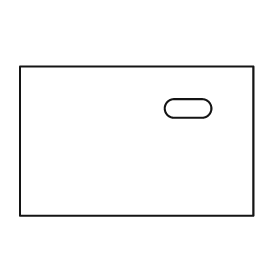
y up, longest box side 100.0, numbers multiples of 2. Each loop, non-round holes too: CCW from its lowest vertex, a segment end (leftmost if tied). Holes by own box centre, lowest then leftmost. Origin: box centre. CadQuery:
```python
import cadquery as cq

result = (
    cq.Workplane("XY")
    .moveTo(-50.0, -32.0)
    .lineTo(50.0, -32.0)
    .lineTo(50.0, 32.0)
    .lineTo(-50.0, 32.0)
    .close()
    .moveTo(16.0, 10.0)
    .lineTo(28.0, 10.0)
    .threePointArc((32.0, 14.0), (28.0, 18.0))
    .lineTo(16.0, 18.0)
    .threePointArc((12.0, 14.0), (16.0, 10.0))
    .close()
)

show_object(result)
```